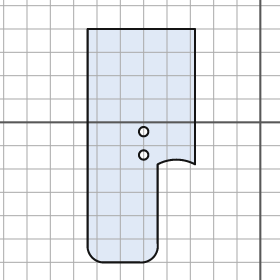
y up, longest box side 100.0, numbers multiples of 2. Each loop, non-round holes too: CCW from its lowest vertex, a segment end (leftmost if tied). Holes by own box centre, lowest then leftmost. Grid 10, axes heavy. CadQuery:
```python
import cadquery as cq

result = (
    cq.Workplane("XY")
    .moveTo(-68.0, -60.0)
    .lineTo(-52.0, -60.0)
    .threePointArc((-46.0, -58.0), (-44.0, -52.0))
    .lineTo(-44.0, -18.0)
    .threePointArc((-36.0, -16.0), (-28.0, -18.0))
    .lineTo(-28.0, 40.0)
    .lineTo(-74.0, 40.0)
    .lineTo(-74.0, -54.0)
    .threePointArc((-72.0, -58.0), (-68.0, -60.0))
    .close()
    .moveTo(-50.0, -14.0)
    .circle(2.0)
    .moveTo(-50.0, -4.0)
    .circle(2.0)
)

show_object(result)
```